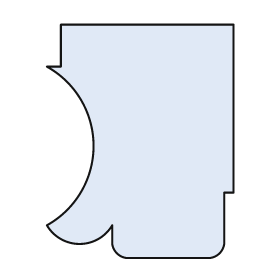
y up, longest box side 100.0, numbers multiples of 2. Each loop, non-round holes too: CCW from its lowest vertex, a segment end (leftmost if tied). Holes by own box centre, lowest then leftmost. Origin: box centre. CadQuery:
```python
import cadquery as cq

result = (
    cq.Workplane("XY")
    .moveTo(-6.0, -50.0)
    .lineTo(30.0, -50.0)
    .threePointArc((34.0, -48.0), (36.0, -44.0))
    .lineTo(36.0, -22.0)
    .lineTo(40.0, -22.0)
    .lineTo(40.0, 50.0)
    .lineTo(-34.0, 50.0)
    .lineTo(-34.0, 32.0)
    .lineTo(-40.0, 32.0)
    .threePointArc((-20.0, -2.0), (-40.0, -36.0))
    .threePointArc((-26.0, -44.0), (-12.0, -36.0))
    .lineTo(-12.0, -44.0)
    .threePointArc((-10.0, -48.0), (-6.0, -50.0))
    .close()
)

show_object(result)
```